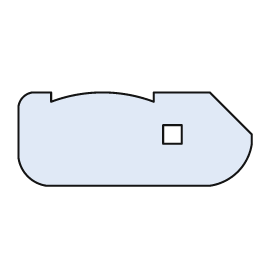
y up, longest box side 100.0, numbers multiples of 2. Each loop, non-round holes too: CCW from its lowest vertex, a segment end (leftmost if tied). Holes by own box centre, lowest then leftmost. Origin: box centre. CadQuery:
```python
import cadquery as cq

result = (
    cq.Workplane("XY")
    .moveTo(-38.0, -20.0)
    .lineTo(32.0, -20.0)
    .threePointArc((44.0, -14.0), (50.0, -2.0))
    .lineTo(50.0, 2.0)
    .lineTo(32.0, 20.0)
    .lineTo(8.0, 20.0)
    .lineTo(8.0, 16.0)
    .threePointArc((-14.0, 20.0), (-36.0, 16.0))
    .lineTo(-36.0, 20.0)
    .lineTo(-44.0, 20.0)
    .threePointArc((-48.0, 18.0), (-50.0, 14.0))
    .lineTo(-50.0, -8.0)
    .threePointArc((-46.0, -16.0), (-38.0, -20.0))
    .close()
    .moveTo(12.0, -2.0)
    .lineTo(20.0, -2.0)
    .lineTo(20.0, 6.0)
    .lineTo(12.0, 6.0)
    .close()
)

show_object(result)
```